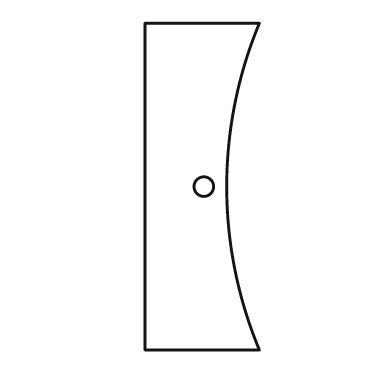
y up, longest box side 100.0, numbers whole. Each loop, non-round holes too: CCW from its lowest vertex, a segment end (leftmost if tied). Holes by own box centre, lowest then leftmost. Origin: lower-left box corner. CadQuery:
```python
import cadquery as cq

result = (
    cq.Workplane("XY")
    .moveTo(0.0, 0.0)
    .lineTo(35.0, 0.0)
    .threePointArc((25.0, 50.0), (35.0, 100.0))
    .lineTo(0.0, 100.0)
    .close()
    .moveTo(18.0, 50.0)
    .circle(3.0)
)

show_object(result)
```